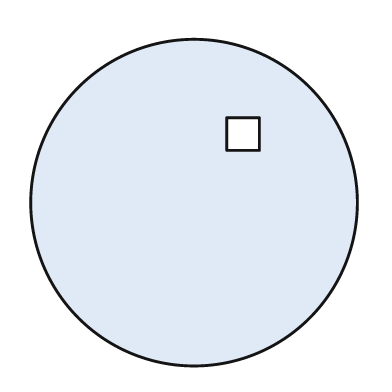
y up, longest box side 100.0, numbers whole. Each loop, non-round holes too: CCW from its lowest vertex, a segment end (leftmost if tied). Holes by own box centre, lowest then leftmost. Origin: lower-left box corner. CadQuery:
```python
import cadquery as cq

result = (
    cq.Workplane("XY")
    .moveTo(50.0, 50.0)
    .circle(50.0)
    .moveTo(60.0, 66.0)
    .lineTo(70.0, 66.0)
    .lineTo(70.0, 76.0)
    .lineTo(60.0, 76.0)
    .close()
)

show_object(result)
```